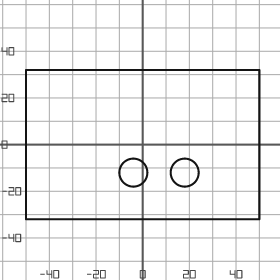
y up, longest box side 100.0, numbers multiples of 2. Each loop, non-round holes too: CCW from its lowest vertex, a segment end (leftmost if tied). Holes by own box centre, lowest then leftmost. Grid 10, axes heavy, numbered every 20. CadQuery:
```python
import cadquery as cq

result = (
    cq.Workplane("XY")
    .moveTo(-50.0, -32.0)
    .lineTo(50.0, -32.0)
    .lineTo(50.0, 32.0)
    .lineTo(-50.0, 32.0)
    .close()
    .moveTo(-4.0, -12.0)
    .circle(6.0)
    .moveTo(18.0, -12.0)
    .circle(6.0)
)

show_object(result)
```